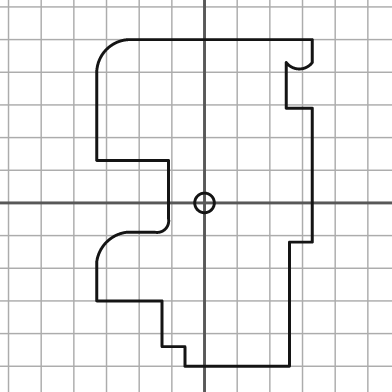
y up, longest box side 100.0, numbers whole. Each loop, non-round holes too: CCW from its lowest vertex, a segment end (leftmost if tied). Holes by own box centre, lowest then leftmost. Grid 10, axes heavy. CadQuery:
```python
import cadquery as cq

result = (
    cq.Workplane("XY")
    .moveTo(-6.0, -50.0)
    .lineTo(26.0, -50.0)
    .lineTo(26.0, -12.0)
    .lineTo(33.0, -12.0)
    .lineTo(33.0, 29.0)
    .lineTo(25.0, 29.0)
    .lineTo(25.0, 43.0)
    .threePointArc((29.0, 41.0), (33.0, 43.0))
    .lineTo(33.0, 50.0)
    .lineTo(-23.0, 50.0)
    .threePointArc((-30.0, 47.0), (-33.0, 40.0))
    .lineTo(-33.0, 13.0)
    .lineTo(-11.0, 13.0)
    .lineTo(-11.0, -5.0)
    .threePointArc((-12.0, -8.0), (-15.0, -9.0))
    .lineTo(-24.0, -9.0)
    .threePointArc((-30.0, -12.0), (-33.0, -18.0))
    .lineTo(-33.0, -30.0)
    .lineTo(-13.0, -30.0)
    .lineTo(-13.0, -44.0)
    .lineTo(-6.0, -44.0)
    .close()
    .moveTo(0.0, 0.0)
    .circle(3.0)
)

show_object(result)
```